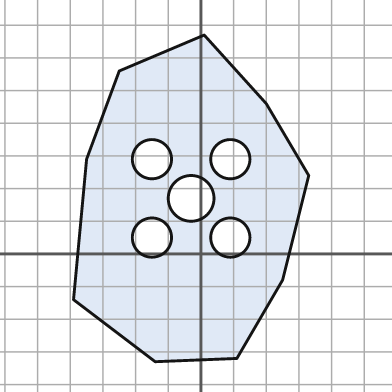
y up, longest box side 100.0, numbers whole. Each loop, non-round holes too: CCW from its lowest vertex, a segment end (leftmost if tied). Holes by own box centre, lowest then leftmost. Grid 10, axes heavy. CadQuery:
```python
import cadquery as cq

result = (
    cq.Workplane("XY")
    .moveTo(-14.0, -33.0)
    .lineTo(11.0, -32.0)
    .lineTo(25.0, -8.0)
    .lineTo(33.0, 24.0)
    .lineTo(20.0, 46.0)
    .lineTo(1.0, 67.0)
    .lineTo(-25.0, 56.0)
    .lineTo(-35.0, 29.0)
    .lineTo(-39.0, -14.0)
    .close()
    .moveTo(-15.0, 5.0)
    .circle(6.0)
    .moveTo(9.0, 5.0)
    .circle(6.0)
    .moveTo(-3.0, 17.0)
    .circle(7.0)
    .moveTo(-15.0, 29.0)
    .circle(6.0)
    .moveTo(9.0, 29.0)
    .circle(6.0)
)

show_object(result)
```